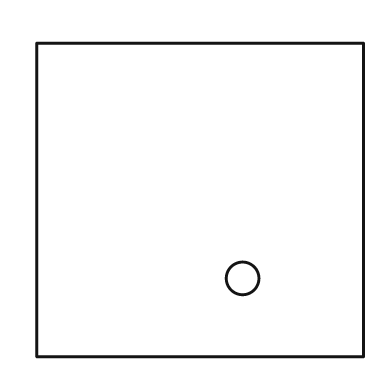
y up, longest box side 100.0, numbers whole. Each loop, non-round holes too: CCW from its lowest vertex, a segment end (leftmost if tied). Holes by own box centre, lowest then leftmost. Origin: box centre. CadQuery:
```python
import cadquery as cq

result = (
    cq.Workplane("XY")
    .moveTo(-50.0, -48.0)
    .lineTo(50.0, -48.0)
    .lineTo(50.0, 48.0)
    .lineTo(-50.0, 48.0)
    .close()
    .moveTo(13.0, -24.0)
    .circle(5.0)
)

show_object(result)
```